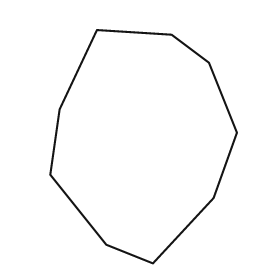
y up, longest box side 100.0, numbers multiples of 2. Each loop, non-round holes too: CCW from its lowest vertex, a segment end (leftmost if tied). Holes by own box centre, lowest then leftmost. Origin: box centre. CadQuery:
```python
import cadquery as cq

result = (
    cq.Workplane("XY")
    .moveTo(4.0, -50.0)
    .lineTo(30.0, -22.0)
    .lineTo(40.0, 6.0)
    .lineTo(28.0, 36.0)
    .lineTo(12.0, 48.0)
    .lineTo(-20.0, 50.0)
    .lineTo(-36.0, 16.0)
    .lineTo(-40.0, -12.0)
    .lineTo(-16.0, -42.0)
    .close()
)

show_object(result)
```